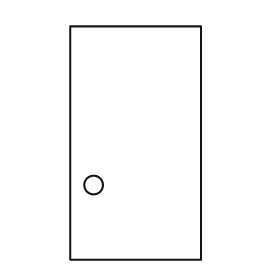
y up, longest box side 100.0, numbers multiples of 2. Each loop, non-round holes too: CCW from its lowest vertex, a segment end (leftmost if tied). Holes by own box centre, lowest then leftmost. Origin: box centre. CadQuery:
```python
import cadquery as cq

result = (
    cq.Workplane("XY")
    .moveTo(-28.0, -50.0)
    .lineTo(28.0, -50.0)
    .lineTo(28.0, 50.0)
    .lineTo(-28.0, 50.0)
    .close()
    .moveTo(-18.0, -18.0)
    .circle(4.0)
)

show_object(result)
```